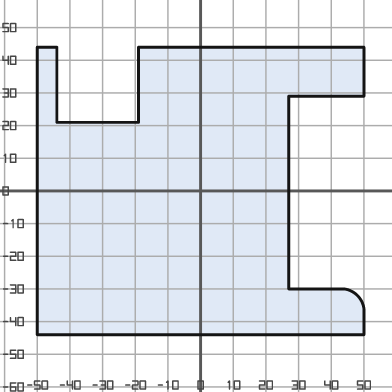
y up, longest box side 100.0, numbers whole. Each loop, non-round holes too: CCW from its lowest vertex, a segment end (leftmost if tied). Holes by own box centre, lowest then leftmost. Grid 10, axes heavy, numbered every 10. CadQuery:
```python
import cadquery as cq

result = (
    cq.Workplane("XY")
    .moveTo(-50.0, -44.0)
    .lineTo(50.0, -44.0)
    .lineTo(50.0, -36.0)
    .threePointArc((48.0, -32.0), (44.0, -30.0))
    .lineTo(27.0, -30.0)
    .lineTo(27.0, 29.0)
    .lineTo(50.0, 29.0)
    .lineTo(50.0, 44.0)
    .lineTo(-19.0, 44.0)
    .lineTo(-19.0, 21.0)
    .lineTo(-44.0, 21.0)
    .lineTo(-44.0, 44.0)
    .lineTo(-50.0, 44.0)
    .close()
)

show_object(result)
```